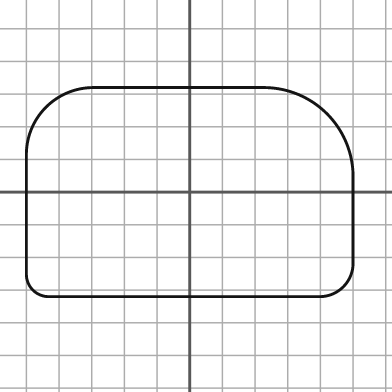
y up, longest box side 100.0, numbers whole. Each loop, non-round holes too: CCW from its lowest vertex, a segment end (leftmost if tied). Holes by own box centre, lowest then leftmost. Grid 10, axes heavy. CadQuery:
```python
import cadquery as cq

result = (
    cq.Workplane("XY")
    .moveTo(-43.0, -32.0)
    .lineTo(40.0, -32.0)
    .threePointArc((47.0, -29.0), (50.0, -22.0))
    .lineTo(50.0, 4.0)
    .threePointArc((42.0, 24.0), (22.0, 32.0))
    .lineTo(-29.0, 32.0)
    .threePointArc((-44.0, 26.0), (-50.0, 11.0))
    .lineTo(-50.0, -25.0)
    .threePointArc((-48.0, -30.0), (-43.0, -32.0))
    .close()
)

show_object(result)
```